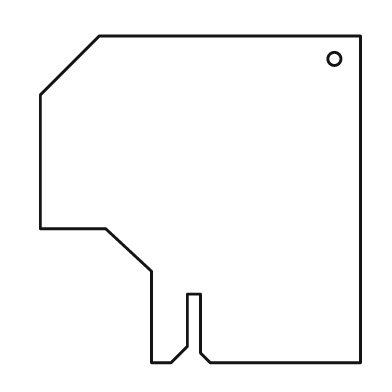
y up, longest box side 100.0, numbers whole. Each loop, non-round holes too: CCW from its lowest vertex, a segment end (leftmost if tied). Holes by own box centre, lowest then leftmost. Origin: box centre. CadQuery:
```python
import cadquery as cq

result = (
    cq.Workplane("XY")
    .moveTo(-15.0, -50.0)
    .lineTo(-9.0, -50.0)
    .lineTo(-4.0, -45.0)
    .lineTo(-4.0, -29.0)
    .lineTo(0.0, -29.0)
    .lineTo(0.0, -47.0)
    .lineTo(3.0, -50.0)
    .lineTo(49.0, -50.0)
    .lineTo(49.0, 50.0)
    .lineTo(-31.0, 50.0)
    .lineTo(-49.0, 32.0)
    .lineTo(-49.0, -9.0)
    .lineTo(-29.0, -9.0)
    .lineTo(-15.0, -22.0)
    .close()
    .moveTo(41.0, 43.0)
    .circle(2.0)
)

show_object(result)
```